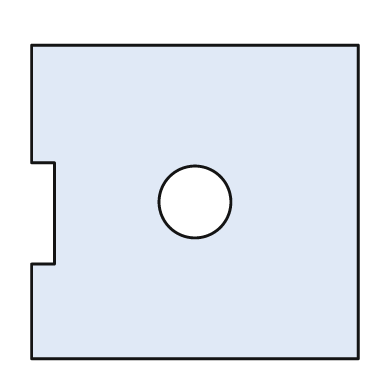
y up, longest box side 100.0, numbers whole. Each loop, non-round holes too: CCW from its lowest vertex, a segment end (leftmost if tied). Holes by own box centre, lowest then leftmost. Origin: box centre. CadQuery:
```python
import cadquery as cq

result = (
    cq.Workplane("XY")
    .moveTo(-50.0, -48.0)
    .lineTo(50.0, -48.0)
    .lineTo(50.0, 48.0)
    .lineTo(-50.0, 48.0)
    .lineTo(-50.0, 12.0)
    .lineTo(-43.0, 12.0)
    .lineTo(-43.0, -19.0)
    .lineTo(-50.0, -19.0)
    .close()
    .moveTo(0.0, 0.0)
    .circle(11.0)
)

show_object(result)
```